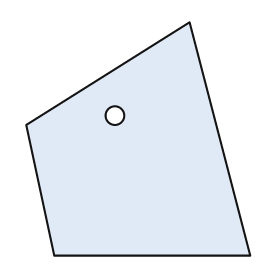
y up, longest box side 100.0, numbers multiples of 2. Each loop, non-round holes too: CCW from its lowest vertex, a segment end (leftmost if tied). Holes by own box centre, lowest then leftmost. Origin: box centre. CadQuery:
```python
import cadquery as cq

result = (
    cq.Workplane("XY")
    .moveTo(-36.0, -50.0)
    .lineTo(48.0, -50.0)
    .lineTo(22.0, 50.0)
    .lineTo(-48.0, 6.0)
    .close()
    .moveTo(-10.0, 10.0)
    .circle(4.0)
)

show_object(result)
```